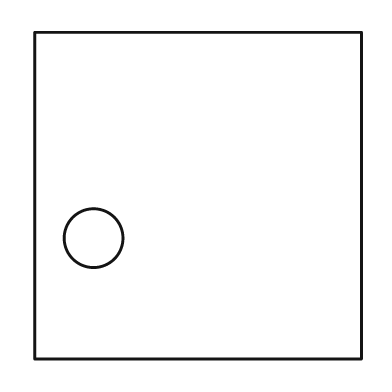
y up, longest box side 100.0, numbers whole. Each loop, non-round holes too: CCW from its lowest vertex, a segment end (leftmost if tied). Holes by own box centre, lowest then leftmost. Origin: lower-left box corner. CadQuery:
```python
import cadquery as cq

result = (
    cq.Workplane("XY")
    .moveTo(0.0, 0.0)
    .lineTo(100.0, 0.0)
    .lineTo(100.0, 100.0)
    .lineTo(0.0, 100.0)
    .close()
    .moveTo(18.0, 37.0)
    .circle(9.0)
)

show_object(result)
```